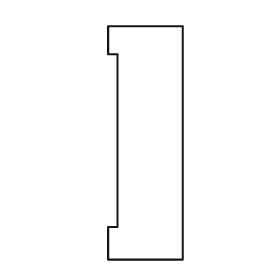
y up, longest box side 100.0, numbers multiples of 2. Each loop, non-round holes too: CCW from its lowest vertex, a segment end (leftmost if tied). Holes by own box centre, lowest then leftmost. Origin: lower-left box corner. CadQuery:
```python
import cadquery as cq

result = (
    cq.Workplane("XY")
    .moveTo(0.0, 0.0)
    .lineTo(32.0, 0.0)
    .lineTo(32.0, 100.0)
    .lineTo(0.0, 100.0)
    .lineTo(0.0, 88.0)
    .lineTo(4.0, 88.0)
    .lineTo(4.0, 14.0)
    .lineTo(0.0, 14.0)
    .close()
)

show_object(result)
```